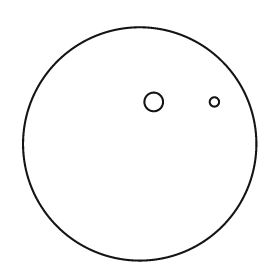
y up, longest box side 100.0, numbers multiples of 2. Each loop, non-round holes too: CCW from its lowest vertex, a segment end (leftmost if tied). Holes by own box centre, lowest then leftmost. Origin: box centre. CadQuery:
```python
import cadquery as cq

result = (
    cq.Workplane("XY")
    .moveTo(0.0, 0.0)
    .circle(50.0)
    .moveTo(6.0, 18.0)
    .circle(4.0)
    .moveTo(32.0, 18.0)
    .circle(2.0)
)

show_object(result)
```